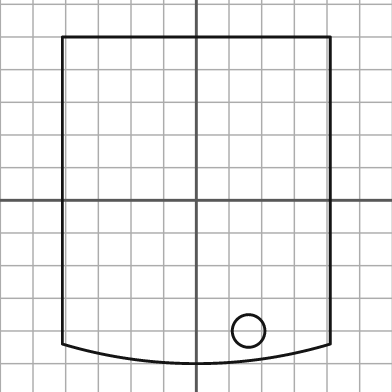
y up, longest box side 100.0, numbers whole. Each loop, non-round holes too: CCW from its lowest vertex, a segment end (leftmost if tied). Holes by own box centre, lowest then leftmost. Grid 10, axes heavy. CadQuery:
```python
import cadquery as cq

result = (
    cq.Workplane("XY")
    .moveTo(-41.0, -44.0)
    .threePointArc((0.0, -50.0), (41.0, -44.0))
    .lineTo(41.0, 50.0)
    .lineTo(-41.0, 50.0)
    .close()
    .moveTo(16.0, -40.0)
    .circle(5.0)
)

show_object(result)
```